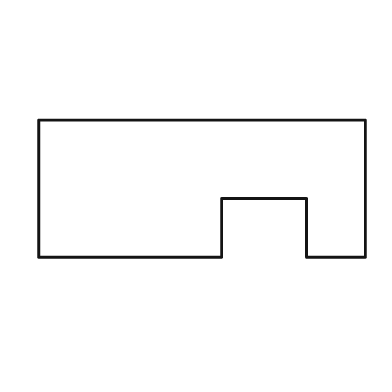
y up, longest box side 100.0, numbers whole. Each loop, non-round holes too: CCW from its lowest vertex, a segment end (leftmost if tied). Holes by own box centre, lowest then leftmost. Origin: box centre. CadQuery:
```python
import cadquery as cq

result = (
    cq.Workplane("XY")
    .moveTo(-50.0, -21.0)
    .lineTo(6.0, -21.0)
    .lineTo(6.0, -3.0)
    .lineTo(32.0, -3.0)
    .lineTo(32.0, -21.0)
    .lineTo(50.0, -21.0)
    .lineTo(50.0, 21.0)
    .lineTo(-50.0, 21.0)
    .close()
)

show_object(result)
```